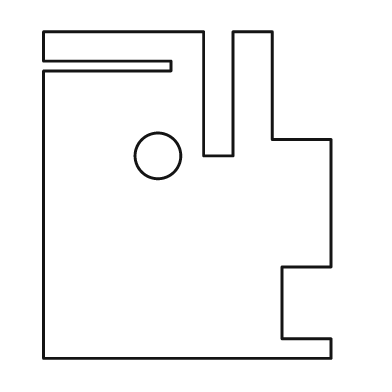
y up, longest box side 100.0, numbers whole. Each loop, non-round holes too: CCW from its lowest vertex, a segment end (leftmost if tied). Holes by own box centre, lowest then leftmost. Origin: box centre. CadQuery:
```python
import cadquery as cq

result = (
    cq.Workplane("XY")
    .moveTo(-44.0, -50.0)
    .lineTo(44.0, -50.0)
    .lineTo(44.0, -44.0)
    .lineTo(29.0, -44.0)
    .lineTo(29.0, -22.0)
    .lineTo(44.0, -22.0)
    .lineTo(44.0, 17.0)
    .lineTo(26.0, 17.0)
    .lineTo(26.0, 50.0)
    .lineTo(14.0, 50.0)
    .lineTo(14.0, 12.0)
    .lineTo(5.0, 12.0)
    .lineTo(5.0, 50.0)
    .lineTo(-44.0, 50.0)
    .lineTo(-44.0, 41.0)
    .lineTo(-5.0, 41.0)
    .lineTo(-5.0, 38.0)
    .lineTo(-44.0, 38.0)
    .close()
    .moveTo(-9.0, 12.0)
    .circle(7.0)
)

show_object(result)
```